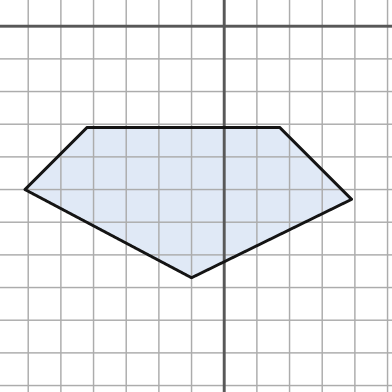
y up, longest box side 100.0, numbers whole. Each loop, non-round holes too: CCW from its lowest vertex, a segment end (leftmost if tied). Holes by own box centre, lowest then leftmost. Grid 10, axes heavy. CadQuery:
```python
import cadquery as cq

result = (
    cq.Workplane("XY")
    .moveTo(-10.0, -77.0)
    .lineTo(39.0, -53.0)
    .lineTo(17.0, -31.0)
    .lineTo(-42.0, -31.0)
    .lineTo(-61.0, -50.0)
    .close()
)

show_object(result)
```